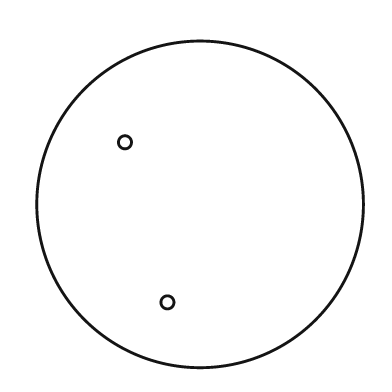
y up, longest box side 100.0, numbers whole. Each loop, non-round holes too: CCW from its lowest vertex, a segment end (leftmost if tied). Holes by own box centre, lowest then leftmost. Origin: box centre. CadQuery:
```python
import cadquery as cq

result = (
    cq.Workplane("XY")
    .moveTo(0.0, 0.0)
    .circle(50.0)
    .moveTo(-10.0, -30.0)
    .circle(2.0)
    .moveTo(-23.0, 19.0)
    .circle(2.0)
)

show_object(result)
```